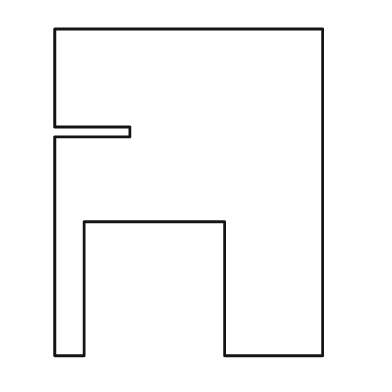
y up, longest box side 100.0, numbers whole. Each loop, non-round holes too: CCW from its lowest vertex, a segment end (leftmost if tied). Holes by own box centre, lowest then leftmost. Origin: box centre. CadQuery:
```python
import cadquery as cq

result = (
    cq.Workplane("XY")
    .moveTo(-41.0, -50.0)
    .lineTo(-32.0, -50.0)
    .lineTo(-32.0, -9.0)
    .lineTo(11.0, -9.0)
    .lineTo(11.0, -50.0)
    .lineTo(41.0, -50.0)
    .lineTo(41.0, 50.0)
    .lineTo(-41.0, 50.0)
    .lineTo(-41.0, 20.0)
    .lineTo(-18.0, 20.0)
    .lineTo(-18.0, 17.0)
    .lineTo(-41.0, 17.0)
    .close()
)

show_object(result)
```